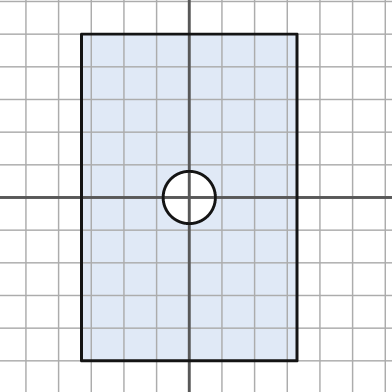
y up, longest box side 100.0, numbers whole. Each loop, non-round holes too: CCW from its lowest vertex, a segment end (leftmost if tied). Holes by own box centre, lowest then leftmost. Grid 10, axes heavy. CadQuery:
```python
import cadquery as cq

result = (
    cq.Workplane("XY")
    .moveTo(-33.0, -50.0)
    .lineTo(33.0, -50.0)
    .lineTo(33.0, 50.0)
    .lineTo(-33.0, 50.0)
    .close()
    .moveTo(0.0, 0.0)
    .circle(8.0)
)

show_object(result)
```